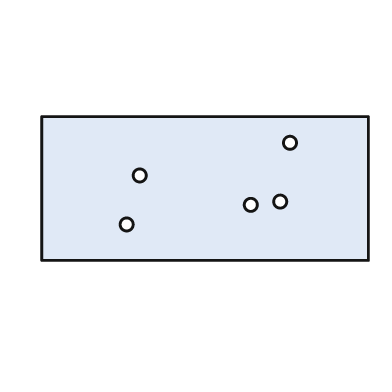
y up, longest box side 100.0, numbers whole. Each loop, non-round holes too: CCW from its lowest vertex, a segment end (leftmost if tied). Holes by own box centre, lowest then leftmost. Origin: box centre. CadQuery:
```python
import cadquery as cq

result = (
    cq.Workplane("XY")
    .moveTo(-50.0, -22.0)
    .lineTo(50.0, -22.0)
    .lineTo(50.0, 22.0)
    .lineTo(-50.0, 22.0)
    .close()
    .moveTo(-24.0, -11.0)
    .circle(2.0)
    .moveTo(14.0, -5.0)
    .circle(2.0)
    .moveTo(23.0, -4.0)
    .circle(2.0)
    .moveTo(-20.0, 4.0)
    .circle(2.0)
    .moveTo(26.0, 14.0)
    .circle(2.0)
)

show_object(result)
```